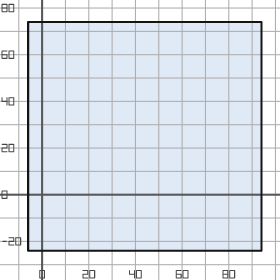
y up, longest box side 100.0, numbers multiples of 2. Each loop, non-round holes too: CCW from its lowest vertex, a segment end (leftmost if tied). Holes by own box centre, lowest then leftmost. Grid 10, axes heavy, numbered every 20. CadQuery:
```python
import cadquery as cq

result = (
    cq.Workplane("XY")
    .moveTo(-6.0, -24.0)
    .lineTo(94.0, -24.0)
    .lineTo(94.0, 74.0)
    .lineTo(-6.0, 74.0)
    .close()
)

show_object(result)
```